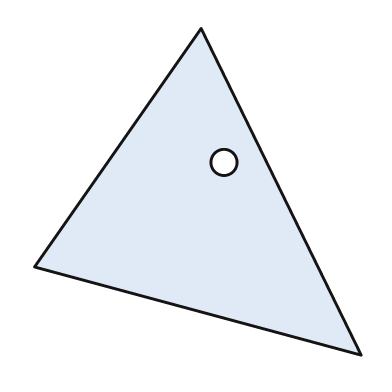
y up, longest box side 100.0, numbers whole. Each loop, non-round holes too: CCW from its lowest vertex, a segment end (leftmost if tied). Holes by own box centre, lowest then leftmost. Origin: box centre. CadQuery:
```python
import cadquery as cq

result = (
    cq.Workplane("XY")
    .moveTo(50.0, -50.0)
    .lineTo(1.0, 50.0)
    .lineTo(-50.0, -23.0)
    .close()
    .moveTo(8.0, 9.0)
    .circle(4.0)
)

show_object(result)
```